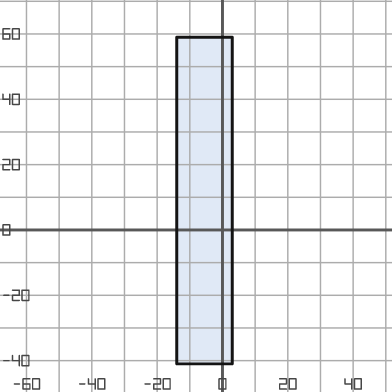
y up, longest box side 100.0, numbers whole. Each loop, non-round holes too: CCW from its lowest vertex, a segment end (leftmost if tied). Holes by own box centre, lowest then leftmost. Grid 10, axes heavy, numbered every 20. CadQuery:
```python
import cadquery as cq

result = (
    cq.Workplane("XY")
    .moveTo(-14.0, -41.0)
    .lineTo(3.0, -41.0)
    .lineTo(3.0, 59.0)
    .lineTo(-14.0, 59.0)
    .close()
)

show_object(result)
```